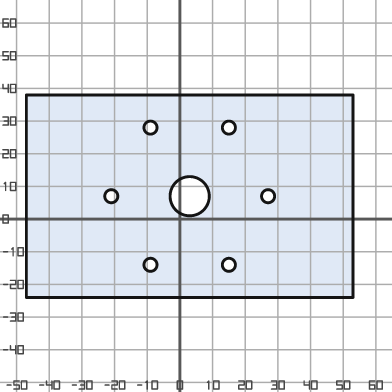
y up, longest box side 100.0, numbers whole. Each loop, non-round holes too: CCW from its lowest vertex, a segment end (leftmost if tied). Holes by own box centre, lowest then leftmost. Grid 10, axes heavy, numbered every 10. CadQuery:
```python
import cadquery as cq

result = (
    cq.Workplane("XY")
    .moveTo(-47.0, -24.0)
    .lineTo(53.0, -24.0)
    .lineTo(53.0, 38.0)
    .lineTo(-47.0, 38.0)
    .close()
    .moveTo(-9.0, -14.0)
    .circle(2.0)
    .moveTo(15.0, -14.0)
    .circle(2.0)
    .moveTo(-21.0, 7.0)
    .circle(2.0)
    .moveTo(3.0, 7.0)
    .circle(6.0)
    .moveTo(27.0, 7.0)
    .circle(2.0)
    .moveTo(-9.0, 28.0)
    .circle(2.0)
    .moveTo(15.0, 28.0)
    .circle(2.0)
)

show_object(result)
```